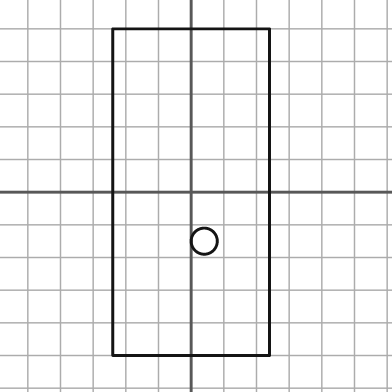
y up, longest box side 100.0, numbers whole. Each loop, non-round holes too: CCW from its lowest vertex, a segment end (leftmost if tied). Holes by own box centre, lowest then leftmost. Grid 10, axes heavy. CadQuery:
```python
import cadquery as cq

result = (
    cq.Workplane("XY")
    .moveTo(-24.0, -50.0)
    .lineTo(24.0, -50.0)
    .lineTo(24.0, 50.0)
    .lineTo(-24.0, 50.0)
    .close()
    .moveTo(4.0, -15.0)
    .circle(4.0)
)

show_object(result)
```